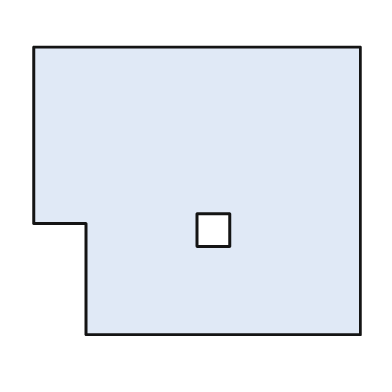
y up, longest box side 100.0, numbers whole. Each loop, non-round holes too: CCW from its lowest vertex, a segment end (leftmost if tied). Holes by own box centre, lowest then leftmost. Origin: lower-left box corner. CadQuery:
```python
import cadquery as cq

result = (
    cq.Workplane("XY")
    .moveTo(16.0, 0.0)
    .lineTo(100.0, 0.0)
    .lineTo(100.0, 88.0)
    .lineTo(0.0, 88.0)
    .lineTo(0.0, 34.0)
    .lineTo(16.0, 34.0)
    .close()
    .moveTo(50.0, 27.0)
    .lineTo(60.0, 27.0)
    .lineTo(60.0, 37.0)
    .lineTo(50.0, 37.0)
    .close()
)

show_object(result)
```